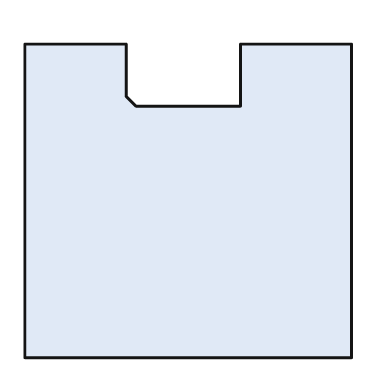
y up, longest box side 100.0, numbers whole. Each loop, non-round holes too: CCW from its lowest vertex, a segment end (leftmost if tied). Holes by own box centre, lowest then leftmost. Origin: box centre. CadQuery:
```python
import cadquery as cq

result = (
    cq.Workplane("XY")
    .moveTo(-50.0, -48.0)
    .lineTo(50.0, -48.0)
    .lineTo(50.0, 48.0)
    .lineTo(16.0, 48.0)
    .lineTo(16.0, 29.0)
    .lineTo(-16.0, 29.0)
    .lineTo(-19.0, 32.0)
    .lineTo(-19.0, 48.0)
    .lineTo(-50.0, 48.0)
    .close()
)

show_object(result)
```